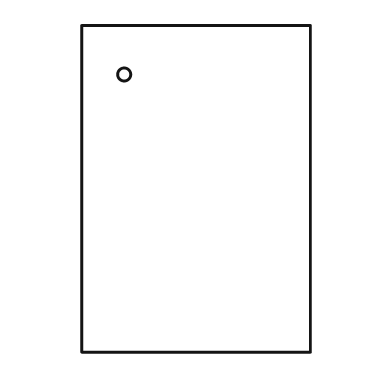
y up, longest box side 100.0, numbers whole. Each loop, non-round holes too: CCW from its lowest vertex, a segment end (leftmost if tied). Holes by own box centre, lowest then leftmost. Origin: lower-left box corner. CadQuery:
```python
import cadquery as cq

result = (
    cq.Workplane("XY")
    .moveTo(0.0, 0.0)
    .lineTo(70.0, 0.0)
    .lineTo(70.0, 100.0)
    .lineTo(0.0, 100.0)
    .close()
    .moveTo(13.0, 85.0)
    .circle(2.0)
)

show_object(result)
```